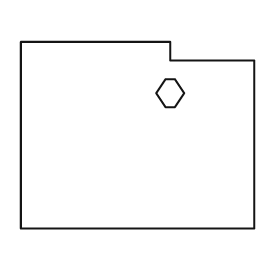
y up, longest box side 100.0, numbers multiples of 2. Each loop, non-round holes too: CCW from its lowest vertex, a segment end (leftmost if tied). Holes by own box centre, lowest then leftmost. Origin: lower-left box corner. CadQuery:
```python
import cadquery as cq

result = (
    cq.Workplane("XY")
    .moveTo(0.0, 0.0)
    .lineTo(100.0, 0.0)
    .lineTo(100.0, 72.0)
    .lineTo(64.0, 72.0)
    .lineTo(64.0, 80.0)
    .lineTo(0.0, 80.0)
    .close()
    .moveTo(62.0, 52.0)
    .lineTo(66.0, 52.0)
    .lineTo(70.0, 58.0)
    .lineTo(66.0, 64.0)
    .lineTo(62.0, 64.0)
    .lineTo(58.0, 58.0)
    .close()
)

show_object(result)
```